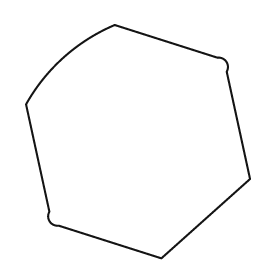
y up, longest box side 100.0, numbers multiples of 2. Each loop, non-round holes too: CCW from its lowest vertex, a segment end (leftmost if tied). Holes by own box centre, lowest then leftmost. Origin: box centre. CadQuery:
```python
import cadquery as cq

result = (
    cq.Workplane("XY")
    .moveTo(10.0, -50.0)
    .lineTo(48.0, -16.0)
    .lineTo(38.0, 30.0)
    .threePointArc((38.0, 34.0), (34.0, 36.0))
    .lineTo(-10.0, 50.0)
    .threePointArc((-32.0, 36.0), (-48.0, 16.0))
    .lineTo(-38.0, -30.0)
    .threePointArc((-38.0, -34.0), (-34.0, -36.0))
    .close()
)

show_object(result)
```